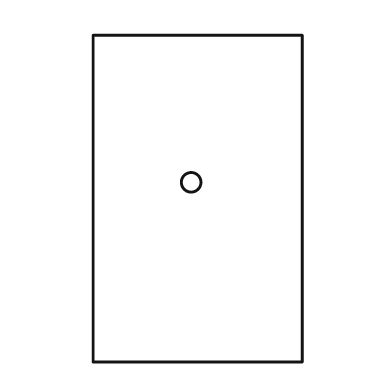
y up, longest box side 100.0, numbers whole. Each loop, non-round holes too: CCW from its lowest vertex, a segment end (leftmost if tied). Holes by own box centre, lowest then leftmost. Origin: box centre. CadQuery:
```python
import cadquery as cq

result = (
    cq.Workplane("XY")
    .moveTo(-32.0, -50.0)
    .lineTo(32.0, -50.0)
    .lineTo(32.0, 50.0)
    .lineTo(-32.0, 50.0)
    .close()
    .moveTo(-2.0, 5.0)
    .circle(3.0)
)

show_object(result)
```